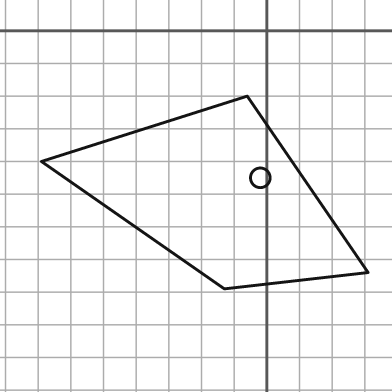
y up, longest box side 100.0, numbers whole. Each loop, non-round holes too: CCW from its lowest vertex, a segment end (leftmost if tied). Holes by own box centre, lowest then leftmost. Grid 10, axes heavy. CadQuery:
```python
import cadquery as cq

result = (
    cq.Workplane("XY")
    .moveTo(-13.0, -79.0)
    .lineTo(31.0, -74.0)
    .lineTo(-6.0, -20.0)
    .lineTo(-69.0, -40.0)
    .close()
    .moveTo(-2.0, -45.0)
    .circle(3.0)
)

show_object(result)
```